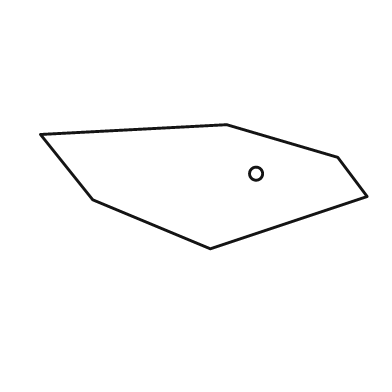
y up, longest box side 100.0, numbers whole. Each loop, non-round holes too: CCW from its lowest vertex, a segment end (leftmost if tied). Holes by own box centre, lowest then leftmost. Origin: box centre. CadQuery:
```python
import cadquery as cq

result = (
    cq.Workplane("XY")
    .moveTo(2.0, -19.0)
    .lineTo(50.0, -3.0)
    .lineTo(41.0, 9.0)
    .lineTo(7.0, 19.0)
    .lineTo(-50.0, 16.0)
    .lineTo(-34.0, -4.0)
    .close()
    .moveTo(16.0, 4.0)
    .circle(2.0)
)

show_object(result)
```